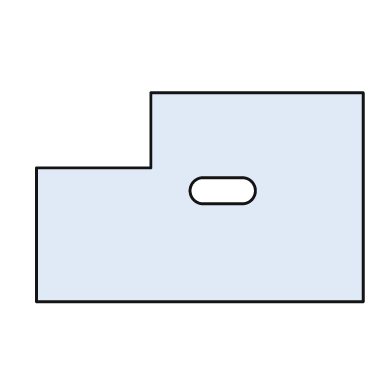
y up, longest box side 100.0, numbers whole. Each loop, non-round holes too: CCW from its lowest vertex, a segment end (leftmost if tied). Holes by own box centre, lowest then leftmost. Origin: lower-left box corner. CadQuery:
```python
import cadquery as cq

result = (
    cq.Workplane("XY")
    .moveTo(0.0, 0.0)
    .lineTo(100.0, 0.0)
    .lineTo(100.0, 64.0)
    .lineTo(35.0, 64.0)
    .lineTo(35.0, 41.0)
    .lineTo(0.0, 41.0)
    .close()
    .moveTo(51.0, 30.0)
    .lineTo(63.0, 30.0)
    .threePointArc((67.0, 34.0), (63.0, 38.0))
    .lineTo(51.0, 38.0)
    .threePointArc((47.0, 34.0), (51.0, 30.0))
    .close()
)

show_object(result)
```